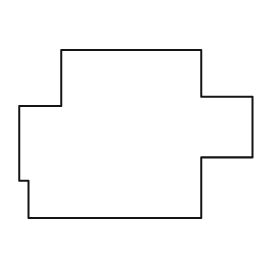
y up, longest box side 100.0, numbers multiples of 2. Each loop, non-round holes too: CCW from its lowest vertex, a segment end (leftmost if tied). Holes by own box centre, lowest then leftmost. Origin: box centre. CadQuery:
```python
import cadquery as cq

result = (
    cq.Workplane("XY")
    .moveTo(-46.0, -36.0)
    .lineTo(28.0, -36.0)
    .lineTo(28.0, -10.0)
    .lineTo(50.0, -10.0)
    .lineTo(50.0, 16.0)
    .lineTo(28.0, 16.0)
    .lineTo(28.0, 36.0)
    .lineTo(-32.0, 36.0)
    .lineTo(-32.0, 12.0)
    .lineTo(-50.0, 12.0)
    .lineTo(-50.0, -20.0)
    .lineTo(-46.0, -20.0)
    .close()
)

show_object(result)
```